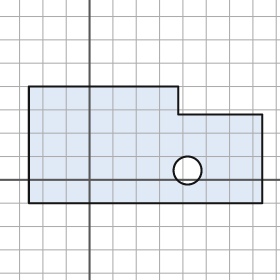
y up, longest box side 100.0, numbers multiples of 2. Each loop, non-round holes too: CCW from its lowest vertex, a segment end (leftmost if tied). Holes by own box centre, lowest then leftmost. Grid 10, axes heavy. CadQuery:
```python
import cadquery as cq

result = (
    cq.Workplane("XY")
    .moveTo(-26.0, -10.0)
    .lineTo(74.0, -10.0)
    .lineTo(74.0, 28.0)
    .lineTo(38.0, 28.0)
    .lineTo(38.0, 40.0)
    .lineTo(-26.0, 40.0)
    .close()
    .moveTo(42.0, 4.0)
    .circle(6.0)
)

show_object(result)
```